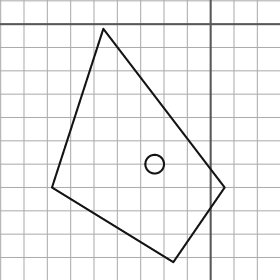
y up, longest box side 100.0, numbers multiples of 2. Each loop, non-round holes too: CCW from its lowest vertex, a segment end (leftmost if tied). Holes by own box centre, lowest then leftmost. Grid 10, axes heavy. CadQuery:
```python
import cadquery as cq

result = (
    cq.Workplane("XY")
    .moveTo(-16.0, -102.0)
    .lineTo(6.0, -70.0)
    .lineTo(-46.0, -2.0)
    .lineTo(-68.0, -70.0)
    .close()
    .moveTo(-24.0, -60.0)
    .circle(4.0)
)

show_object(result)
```